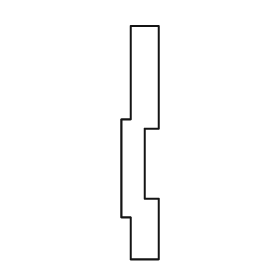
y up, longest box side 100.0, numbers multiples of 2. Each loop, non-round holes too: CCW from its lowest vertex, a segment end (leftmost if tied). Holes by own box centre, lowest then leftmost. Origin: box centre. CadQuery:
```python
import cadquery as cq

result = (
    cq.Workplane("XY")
    .moveTo(-4.0, -50.0)
    .lineTo(8.0, -50.0)
    .lineTo(8.0, -24.0)
    .lineTo(2.0, -24.0)
    .lineTo(2.0, 6.0)
    .lineTo(8.0, 6.0)
    .lineTo(8.0, 50.0)
    .lineTo(-4.0, 50.0)
    .lineTo(-4.0, 10.0)
    .lineTo(-8.0, 10.0)
    .lineTo(-8.0, -32.0)
    .lineTo(-4.0, -32.0)
    .close()
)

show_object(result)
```